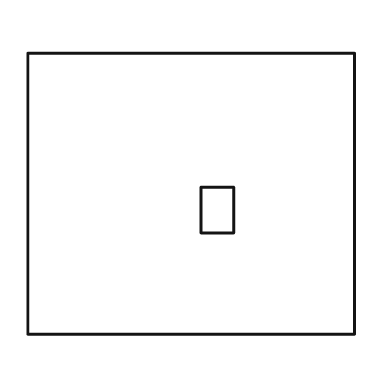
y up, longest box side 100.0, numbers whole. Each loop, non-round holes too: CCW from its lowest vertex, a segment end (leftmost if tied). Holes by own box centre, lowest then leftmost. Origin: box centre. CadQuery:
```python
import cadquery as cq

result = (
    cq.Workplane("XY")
    .moveTo(-50.0, -43.0)
    .lineTo(50.0, -43.0)
    .lineTo(50.0, 43.0)
    .lineTo(-50.0, 43.0)
    .close()
    .moveTo(3.0, -12.0)
    .lineTo(13.0, -12.0)
    .lineTo(13.0, 2.0)
    .lineTo(3.0, 2.0)
    .close()
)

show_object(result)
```